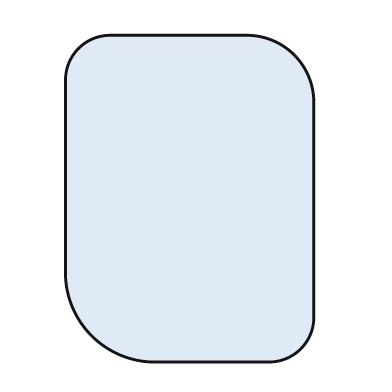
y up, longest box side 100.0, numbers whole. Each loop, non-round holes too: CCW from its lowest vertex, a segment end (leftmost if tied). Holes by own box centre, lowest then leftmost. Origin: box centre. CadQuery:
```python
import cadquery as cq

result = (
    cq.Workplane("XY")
    .moveTo(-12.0, -50.0)
    .lineTo(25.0, -50.0)
    .threePointArc((34.0, -46.0), (38.0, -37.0))
    .lineTo(38.0, 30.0)
    .threePointArc((32.0, 44.0), (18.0, 50.0))
    .lineTo(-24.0, 50.0)
    .threePointArc((-34.0, 46.0), (-38.0, 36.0))
    .lineTo(-38.0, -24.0)
    .threePointArc((-30.0, -42.0), (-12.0, -50.0))
    .close()
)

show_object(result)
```